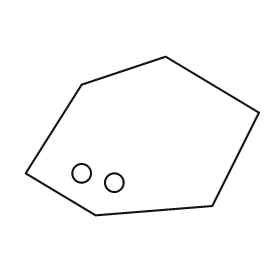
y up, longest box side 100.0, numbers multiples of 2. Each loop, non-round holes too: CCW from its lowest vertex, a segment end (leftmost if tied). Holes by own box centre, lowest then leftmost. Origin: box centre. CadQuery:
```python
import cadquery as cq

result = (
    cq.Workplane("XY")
    .moveTo(-20.0, -34.0)
    .lineTo(30.0, -30.0)
    .lineTo(50.0, 10.0)
    .lineTo(10.0, 34.0)
    .lineTo(-26.0, 22.0)
    .lineTo(-50.0, -16.0)
    .close()
    .moveTo(-12.0, -20.0)
    .circle(4.0)
    .moveTo(-26.0, -16.0)
    .circle(4.0)
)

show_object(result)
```